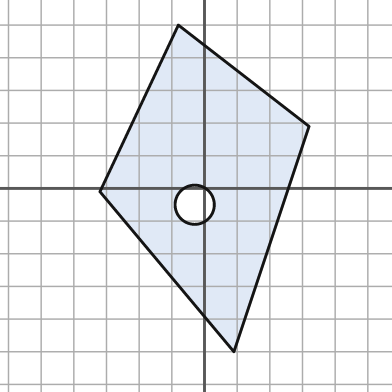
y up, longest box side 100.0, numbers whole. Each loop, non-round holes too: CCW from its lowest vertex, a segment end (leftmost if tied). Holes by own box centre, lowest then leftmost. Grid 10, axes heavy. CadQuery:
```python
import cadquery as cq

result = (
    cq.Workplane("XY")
    .moveTo(9.0, -50.0)
    .lineTo(32.0, 19.0)
    .lineTo(-8.0, 50.0)
    .lineTo(-32.0, -1.0)
    .close()
    .moveTo(-3.0, -5.0)
    .circle(6.0)
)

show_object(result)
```